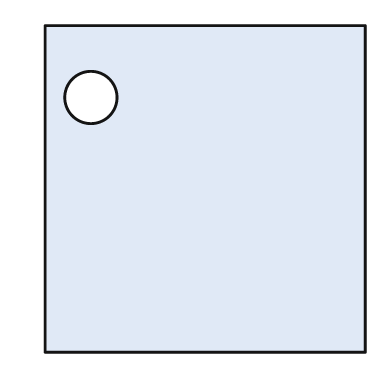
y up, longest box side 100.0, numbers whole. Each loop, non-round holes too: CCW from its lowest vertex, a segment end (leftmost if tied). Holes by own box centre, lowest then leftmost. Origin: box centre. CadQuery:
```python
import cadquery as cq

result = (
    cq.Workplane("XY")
    .moveTo(-49.0, -50.0)
    .lineTo(49.0, -50.0)
    .lineTo(49.0, 50.0)
    .lineTo(-49.0, 50.0)
    .close()
    .moveTo(-35.0, 28.0)
    .circle(8.0)
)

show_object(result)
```